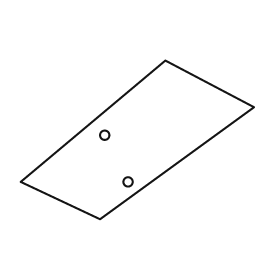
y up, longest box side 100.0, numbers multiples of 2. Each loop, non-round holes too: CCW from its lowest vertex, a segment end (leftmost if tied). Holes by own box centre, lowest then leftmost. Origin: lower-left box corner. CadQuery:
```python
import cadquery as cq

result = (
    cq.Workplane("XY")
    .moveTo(34.0, 0.0)
    .lineTo(100.0, 48.0)
    .lineTo(62.0, 68.0)
    .lineTo(0.0, 16.0)
    .close()
    .moveTo(46.0, 16.0)
    .circle(2.0)
    .moveTo(36.0, 36.0)
    .circle(2.0)
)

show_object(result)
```